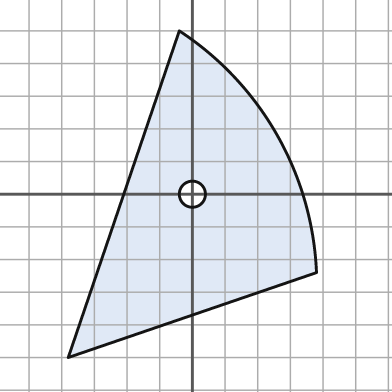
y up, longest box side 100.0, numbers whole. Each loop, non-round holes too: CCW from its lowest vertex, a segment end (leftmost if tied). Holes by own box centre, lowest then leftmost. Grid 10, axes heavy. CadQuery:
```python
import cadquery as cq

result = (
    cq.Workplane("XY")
    .moveTo(-38.0, -50.0)
    .lineTo(38.0, -24.0)
    .threePointArc((26.0, 18.0), (-4.0, 50.0))
    .close()
    .moveTo(0.0, 0.0)
    .circle(4.0)
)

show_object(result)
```